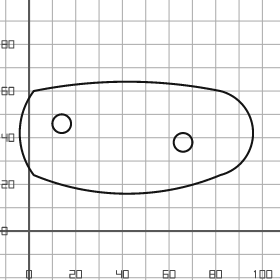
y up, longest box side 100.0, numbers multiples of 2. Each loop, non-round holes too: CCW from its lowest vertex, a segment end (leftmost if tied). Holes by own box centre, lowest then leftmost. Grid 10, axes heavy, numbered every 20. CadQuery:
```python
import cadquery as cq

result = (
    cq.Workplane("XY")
    .moveTo(2.0, 24.0)
    .threePointArc((42.0, 16.0), (82.0, 24.0))
    .threePointArc((96.0, 42.0), (82.0, 60.0))
    .threePointArc((42.0, 64.0), (2.0, 60.0))
    .threePointArc((-4.0, 42.0), (2.0, 24.0))
    .close()
    .moveTo(66.0, 38.0)
    .circle(4.0)
    .moveTo(14.0, 46.0)
    .circle(4.0)
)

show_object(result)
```